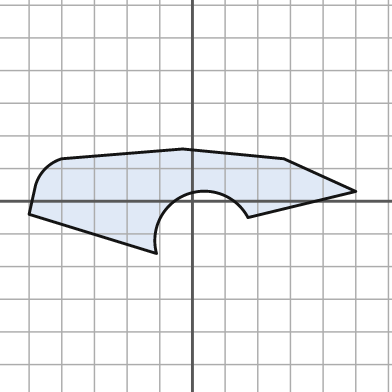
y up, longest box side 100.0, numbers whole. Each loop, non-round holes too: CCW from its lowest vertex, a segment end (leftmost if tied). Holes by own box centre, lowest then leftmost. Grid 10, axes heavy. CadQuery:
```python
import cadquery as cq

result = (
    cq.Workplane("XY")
    .moveTo(-11.0, -16.0)
    .threePointArc((-2.0, 2.0), (17.0, -5.0))
    .lineTo(50.0, 3.0)
    .lineTo(28.0, 13.0)
    .lineTo(-3.0, 16.0)
    .lineTo(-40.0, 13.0)
    .threePointArc((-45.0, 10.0), (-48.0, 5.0))
    .lineTo(-50.0, -4.0)
    .close()
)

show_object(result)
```